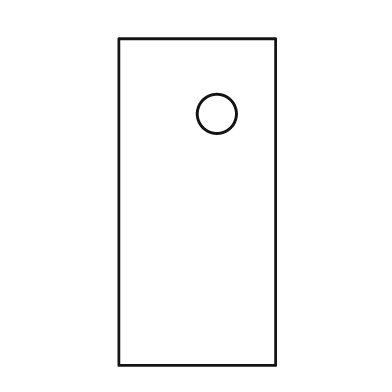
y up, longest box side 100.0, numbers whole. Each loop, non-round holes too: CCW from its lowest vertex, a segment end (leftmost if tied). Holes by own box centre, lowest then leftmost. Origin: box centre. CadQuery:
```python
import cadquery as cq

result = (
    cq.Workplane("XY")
    .moveTo(-24.0, -50.0)
    .lineTo(24.0, -50.0)
    .lineTo(24.0, 50.0)
    .lineTo(-24.0, 50.0)
    .close()
    .moveTo(6.0, 27.0)
    .circle(6.0)
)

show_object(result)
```